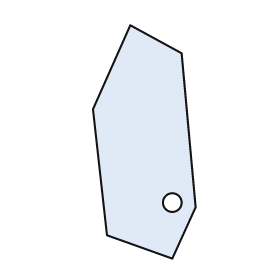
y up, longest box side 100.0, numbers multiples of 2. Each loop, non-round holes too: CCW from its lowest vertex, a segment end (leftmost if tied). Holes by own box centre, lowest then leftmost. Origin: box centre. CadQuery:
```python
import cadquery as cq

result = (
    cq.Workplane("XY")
    .moveTo(12.0, -50.0)
    .lineTo(22.0, -28.0)
    .lineTo(16.0, 38.0)
    .lineTo(-6.0, 50.0)
    .lineTo(-22.0, 14.0)
    .lineTo(-16.0, -40.0)
    .close()
    .moveTo(12.0, -26.0)
    .circle(4.0)
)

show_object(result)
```